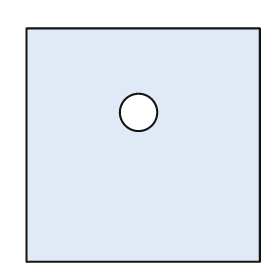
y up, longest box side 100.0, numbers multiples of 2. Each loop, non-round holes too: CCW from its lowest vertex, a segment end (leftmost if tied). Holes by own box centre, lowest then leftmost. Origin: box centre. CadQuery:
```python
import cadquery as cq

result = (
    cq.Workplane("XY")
    .moveTo(-50.0, -50.0)
    .lineTo(50.0, -50.0)
    .lineTo(50.0, 50.0)
    .lineTo(-50.0, 50.0)
    .close()
    .moveTo(-2.0, 14.0)
    .circle(8.0)
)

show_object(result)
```